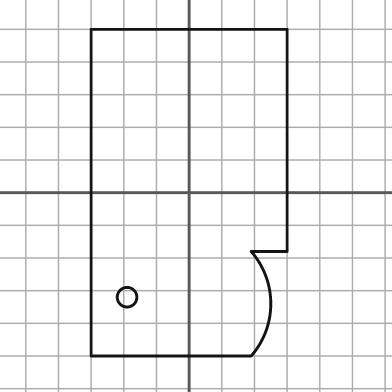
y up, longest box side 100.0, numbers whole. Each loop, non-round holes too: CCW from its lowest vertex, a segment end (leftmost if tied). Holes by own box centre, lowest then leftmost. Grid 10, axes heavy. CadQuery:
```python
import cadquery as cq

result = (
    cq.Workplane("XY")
    .moveTo(-30.0, -50.0)
    .lineTo(19.0, -50.0)
    .threePointArc((25.0, -34.0), (19.0, -18.0))
    .lineTo(30.0, -18.0)
    .lineTo(30.0, 50.0)
    .lineTo(-30.0, 50.0)
    .close()
    .moveTo(-19.0, -32.0)
    .circle(3.0)
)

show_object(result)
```